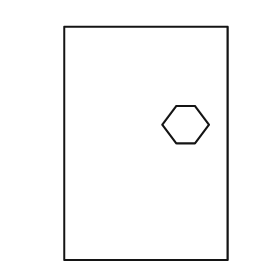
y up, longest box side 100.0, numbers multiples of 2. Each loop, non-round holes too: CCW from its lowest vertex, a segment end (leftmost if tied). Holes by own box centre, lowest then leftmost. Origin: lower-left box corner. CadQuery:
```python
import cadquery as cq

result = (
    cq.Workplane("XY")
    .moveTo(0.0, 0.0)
    .lineTo(70.0, 0.0)
    .lineTo(70.0, 100.0)
    .lineTo(0.0, 100.0)
    .close()
    .moveTo(48.0, 50.0)
    .lineTo(56.0, 50.0)
    .lineTo(62.0, 58.0)
    .lineTo(56.0, 66.0)
    .lineTo(48.0, 66.0)
    .lineTo(42.0, 58.0)
    .close()
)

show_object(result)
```